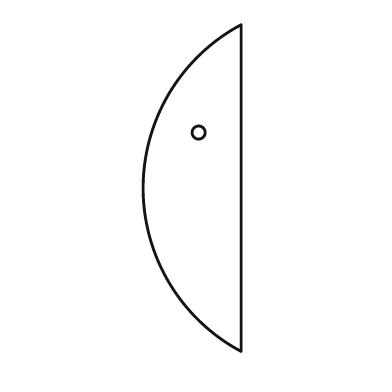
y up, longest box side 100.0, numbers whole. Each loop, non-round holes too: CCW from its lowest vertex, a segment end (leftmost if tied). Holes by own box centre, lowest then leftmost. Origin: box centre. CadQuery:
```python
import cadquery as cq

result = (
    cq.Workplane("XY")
    .moveTo(15.0, -50.0)
    .lineTo(15.0, 50.0)
    .threePointArc((-15.0, 0.0), (15.0, -50.0))
    .close()
    .moveTo(2.0, 17.0)
    .circle(2.0)
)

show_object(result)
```